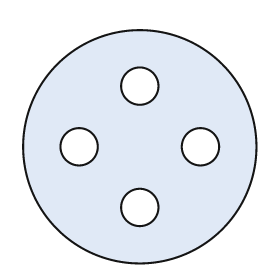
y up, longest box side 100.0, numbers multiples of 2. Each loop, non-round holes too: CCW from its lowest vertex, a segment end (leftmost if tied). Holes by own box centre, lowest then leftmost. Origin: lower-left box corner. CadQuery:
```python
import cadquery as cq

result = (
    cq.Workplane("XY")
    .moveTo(50.0, 50.0)
    .circle(50.0)
    .moveTo(50.0, 24.0)
    .circle(8.0)
    .moveTo(24.0, 50.0)
    .circle(8.0)
    .moveTo(76.0, 50.0)
    .circle(8.0)
    .moveTo(50.0, 76.0)
    .circle(8.0)
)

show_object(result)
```